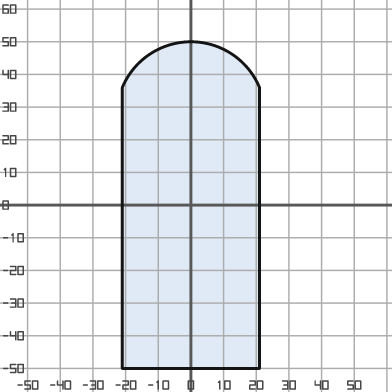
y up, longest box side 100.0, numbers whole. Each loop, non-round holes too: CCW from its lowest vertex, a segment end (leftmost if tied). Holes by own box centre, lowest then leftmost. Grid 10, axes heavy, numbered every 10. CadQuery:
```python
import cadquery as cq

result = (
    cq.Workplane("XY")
    .moveTo(-21.0, -50.0)
    .lineTo(21.0, -50.0)
    .lineTo(21.0, 36.0)
    .threePointArc((0.0, 50.0), (-21.0, 36.0))
    .close()
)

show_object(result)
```